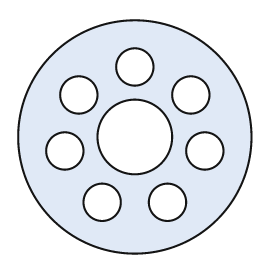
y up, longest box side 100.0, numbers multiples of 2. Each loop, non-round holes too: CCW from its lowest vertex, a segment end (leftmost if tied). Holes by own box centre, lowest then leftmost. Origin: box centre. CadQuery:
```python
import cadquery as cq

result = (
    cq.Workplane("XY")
    .moveTo(0.0, 0.0)
    .circle(50.0)
    .moveTo(-14.0, -28.0)
    .circle(8.0)
    .moveTo(14.0, -28.0)
    .circle(8.0)
    .moveTo(-30.0, -6.0)
    .circle(8.0)
    .moveTo(30.0, -6.0)
    .circle(8.0)
    .moveTo(0.0, 0.0)
    .circle(16.0)
    .moveTo(-24.0, 18.0)
    .circle(8.0)
    .moveTo(24.0, 18.0)
    .circle(8.0)
    .moveTo(0.0, 30.0)
    .circle(8.0)
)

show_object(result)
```